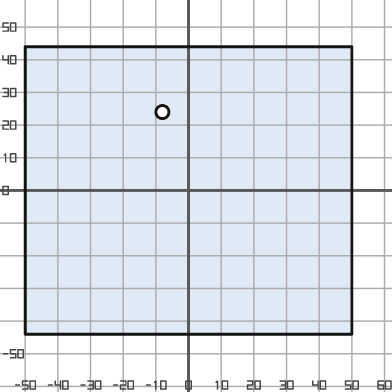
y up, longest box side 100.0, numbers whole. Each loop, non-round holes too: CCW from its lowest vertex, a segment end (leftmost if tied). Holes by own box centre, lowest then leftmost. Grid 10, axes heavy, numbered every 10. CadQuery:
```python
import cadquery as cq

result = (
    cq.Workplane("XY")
    .moveTo(-50.0, -44.0)
    .lineTo(50.0, -44.0)
    .lineTo(50.0, 44.0)
    .lineTo(-50.0, 44.0)
    .close()
    .moveTo(-8.0, 24.0)
    .circle(2.0)
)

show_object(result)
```